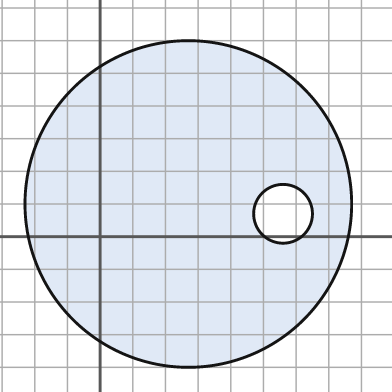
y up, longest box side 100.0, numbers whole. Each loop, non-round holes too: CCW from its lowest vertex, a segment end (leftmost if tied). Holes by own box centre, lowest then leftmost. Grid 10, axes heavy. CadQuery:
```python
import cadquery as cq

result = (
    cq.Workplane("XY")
    .moveTo(27.0, 10.0)
    .circle(50.0)
    .moveTo(56.0, 7.0)
    .circle(9.0)
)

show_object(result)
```